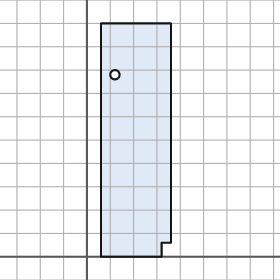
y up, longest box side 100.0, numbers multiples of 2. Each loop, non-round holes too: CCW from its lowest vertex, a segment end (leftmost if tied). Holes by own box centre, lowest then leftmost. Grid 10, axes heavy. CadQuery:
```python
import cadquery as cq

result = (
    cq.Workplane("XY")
    .moveTo(6.0, 0.0)
    .lineTo(32.0, 0.0)
    .lineTo(32.0, 6.0)
    .lineTo(36.0, 6.0)
    .lineTo(36.0, 100.0)
    .lineTo(6.0, 100.0)
    .close()
    .moveTo(12.0, 78.0)
    .circle(2.0)
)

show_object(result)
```